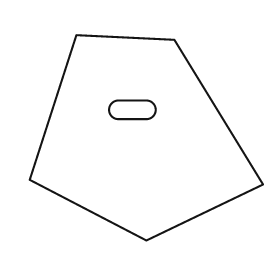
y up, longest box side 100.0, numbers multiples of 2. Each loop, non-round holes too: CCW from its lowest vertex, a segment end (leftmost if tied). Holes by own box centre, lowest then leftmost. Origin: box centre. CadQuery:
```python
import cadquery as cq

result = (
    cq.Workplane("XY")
    .moveTo(0.0, -44.0)
    .lineTo(50.0, -20.0)
    .lineTo(12.0, 42.0)
    .lineTo(-30.0, 44.0)
    .lineTo(-50.0, -18.0)
    .close()
    .moveTo(-12.0, 8.0)
    .lineTo(0.0, 8.0)
    .threePointArc((4.0, 12.0), (0.0, 16.0))
    .lineTo(-12.0, 16.0)
    .threePointArc((-16.0, 12.0), (-12.0, 8.0))
    .close()
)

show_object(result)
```